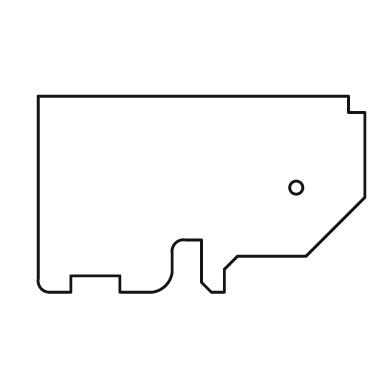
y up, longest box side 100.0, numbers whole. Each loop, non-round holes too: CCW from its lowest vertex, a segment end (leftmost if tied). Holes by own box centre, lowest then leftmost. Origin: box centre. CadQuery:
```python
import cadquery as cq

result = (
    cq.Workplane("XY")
    .moveTo(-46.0, -30.0)
    .lineTo(-40.0, -30.0)
    .lineTo(-40.0, -25.0)
    .lineTo(-25.0, -25.0)
    .lineTo(-25.0, -30.0)
    .lineTo(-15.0, -30.0)
    .threePointArc((-11.0, -28.0), (-9.0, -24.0))
    .lineTo(-9.0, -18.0)
    .threePointArc((-8.0, -15.0), (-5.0, -14.0))
    .lineTo(0.0, -14.0)
    .lineTo(0.0, -27.0)
    .lineTo(3.0, -30.0)
    .lineTo(7.0, -30.0)
    .lineTo(7.0, -23.0)
    .lineTo(11.0, -19.0)
    .lineTo(32.0, -19.0)
    .lineTo(50.0, -1.0)
    .lineTo(50.0, 25.0)
    .lineTo(45.0, 25.0)
    .lineTo(45.0, 30.0)
    .lineTo(-50.0, 30.0)
    .lineTo(-50.0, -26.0)
    .threePointArc((-49.0, -29.0), (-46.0, -30.0))
    .close()
    .moveTo(29.0, 2.0)
    .circle(2.0)
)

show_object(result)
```